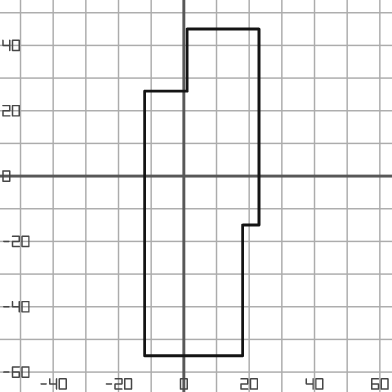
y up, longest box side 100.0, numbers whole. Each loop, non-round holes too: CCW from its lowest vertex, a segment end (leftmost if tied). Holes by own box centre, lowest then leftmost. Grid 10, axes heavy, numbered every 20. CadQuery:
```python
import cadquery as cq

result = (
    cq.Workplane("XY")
    .moveTo(-12.0, -55.0)
    .lineTo(18.0, -55.0)
    .lineTo(18.0, -15.0)
    .lineTo(23.0, -15.0)
    .lineTo(23.0, 45.0)
    .lineTo(1.0, 45.0)
    .lineTo(1.0, 26.0)
    .lineTo(-12.0, 26.0)
    .close()
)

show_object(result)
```